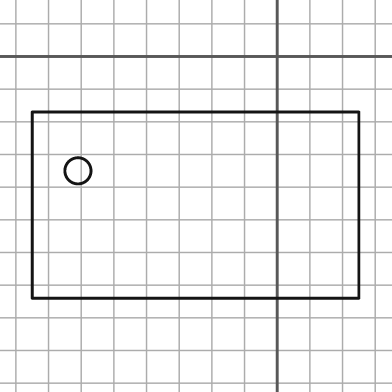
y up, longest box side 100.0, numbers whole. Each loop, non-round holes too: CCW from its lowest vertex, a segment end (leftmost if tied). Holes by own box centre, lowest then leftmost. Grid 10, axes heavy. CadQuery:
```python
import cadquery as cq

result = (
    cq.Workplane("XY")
    .moveTo(-75.0, -74.0)
    .lineTo(25.0, -74.0)
    .lineTo(25.0, -17.0)
    .lineTo(-75.0, -17.0)
    .close()
    .moveTo(-61.0, -35.0)
    .circle(4.0)
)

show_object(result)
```